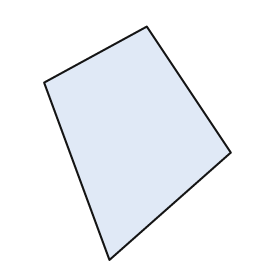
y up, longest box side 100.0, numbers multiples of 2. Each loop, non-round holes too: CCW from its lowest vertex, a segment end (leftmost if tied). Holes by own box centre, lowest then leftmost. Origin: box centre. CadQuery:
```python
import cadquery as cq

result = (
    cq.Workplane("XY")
    .moveTo(-12.0, -50.0)
    .lineTo(40.0, -4.0)
    .lineTo(4.0, 50.0)
    .lineTo(-40.0, 26.0)
    .close()
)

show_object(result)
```